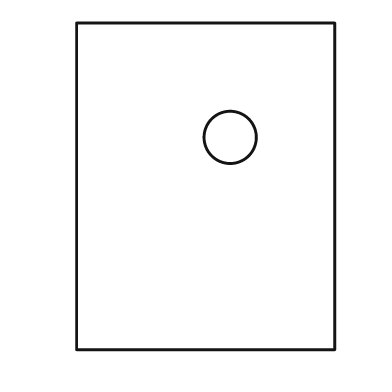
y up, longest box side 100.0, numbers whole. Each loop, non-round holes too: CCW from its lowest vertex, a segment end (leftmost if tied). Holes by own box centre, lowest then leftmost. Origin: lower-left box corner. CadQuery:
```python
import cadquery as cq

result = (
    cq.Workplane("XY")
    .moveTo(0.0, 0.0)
    .lineTo(79.0, 0.0)
    .lineTo(79.0, 100.0)
    .lineTo(0.0, 100.0)
    .close()
    .moveTo(47.0, 65.0)
    .circle(8.0)
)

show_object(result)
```